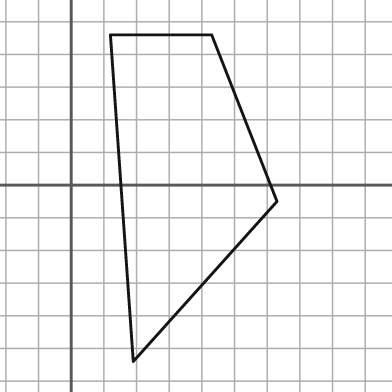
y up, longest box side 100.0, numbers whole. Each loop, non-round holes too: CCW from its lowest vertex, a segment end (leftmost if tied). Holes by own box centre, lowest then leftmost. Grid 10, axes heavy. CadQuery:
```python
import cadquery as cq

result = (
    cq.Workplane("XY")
    .moveTo(19.0, -54.0)
    .lineTo(63.0, -5.0)
    .lineTo(43.0, 46.0)
    .lineTo(12.0, 46.0)
    .close()
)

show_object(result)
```